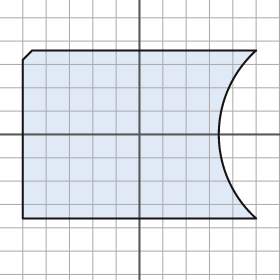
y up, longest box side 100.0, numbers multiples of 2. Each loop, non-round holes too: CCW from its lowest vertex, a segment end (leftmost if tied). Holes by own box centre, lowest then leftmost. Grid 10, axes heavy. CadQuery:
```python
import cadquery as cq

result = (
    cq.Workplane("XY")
    .moveTo(-50.0, -36.0)
    .lineTo(50.0, -36.0)
    .threePointArc((34.0, 0.0), (50.0, 36.0))
    .lineTo(-46.0, 36.0)
    .lineTo(-50.0, 32.0)
    .close()
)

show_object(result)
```